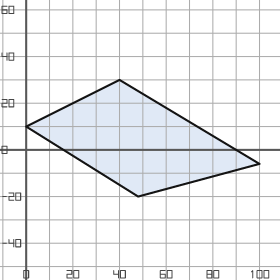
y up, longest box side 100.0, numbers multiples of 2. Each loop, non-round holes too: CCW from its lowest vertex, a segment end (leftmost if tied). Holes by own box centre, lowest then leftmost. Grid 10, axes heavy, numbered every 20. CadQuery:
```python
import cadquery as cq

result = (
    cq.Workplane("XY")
    .moveTo(48.0, -20.0)
    .lineTo(100.0, -6.0)
    .lineTo(40.0, 30.0)
    .lineTo(0.0, 10.0)
    .close()
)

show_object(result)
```